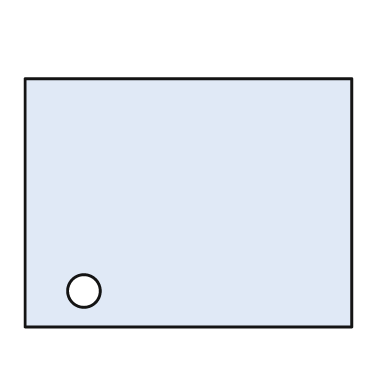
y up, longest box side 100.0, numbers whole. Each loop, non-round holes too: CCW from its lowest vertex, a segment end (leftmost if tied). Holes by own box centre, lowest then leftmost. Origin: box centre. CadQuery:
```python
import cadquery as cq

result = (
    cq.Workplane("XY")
    .moveTo(-50.0, -38.0)
    .lineTo(50.0, -38.0)
    .lineTo(50.0, 38.0)
    .lineTo(-50.0, 38.0)
    .close()
    .moveTo(-32.0, -27.0)
    .circle(5.0)
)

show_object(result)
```